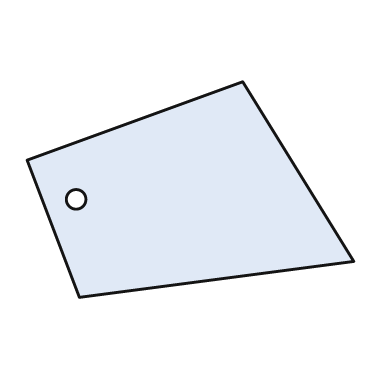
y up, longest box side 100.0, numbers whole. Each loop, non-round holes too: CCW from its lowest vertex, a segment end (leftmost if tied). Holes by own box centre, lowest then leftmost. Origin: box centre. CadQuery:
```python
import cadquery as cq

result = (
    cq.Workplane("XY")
    .moveTo(-34.0, -33.0)
    .lineTo(50.0, -22.0)
    .lineTo(16.0, 33.0)
    .lineTo(-50.0, 9.0)
    .close()
    .moveTo(-35.0, -3.0)
    .circle(3.0)
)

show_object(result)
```